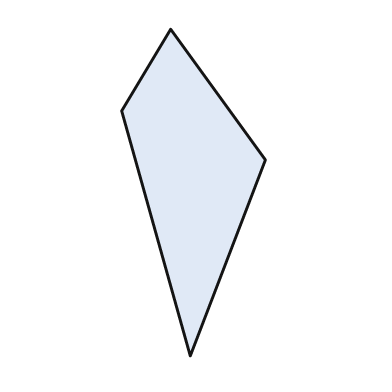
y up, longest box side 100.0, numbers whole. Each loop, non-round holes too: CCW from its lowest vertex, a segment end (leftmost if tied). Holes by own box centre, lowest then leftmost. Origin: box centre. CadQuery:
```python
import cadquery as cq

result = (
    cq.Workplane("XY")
    .moveTo(-1.0, -50.0)
    .lineTo(22.0, 10.0)
    .lineTo(-7.0, 50.0)
    .lineTo(-22.0, 25.0)
    .close()
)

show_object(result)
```